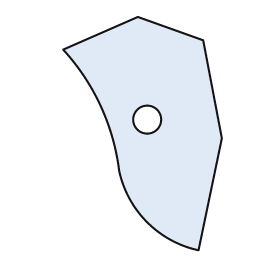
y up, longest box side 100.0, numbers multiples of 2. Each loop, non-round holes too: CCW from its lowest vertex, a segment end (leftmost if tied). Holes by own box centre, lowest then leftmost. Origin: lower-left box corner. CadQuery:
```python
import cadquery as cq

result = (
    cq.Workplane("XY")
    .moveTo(58.0, 0.0)
    .lineTo(68.0, 48.0)
    .lineTo(60.0, 90.0)
    .lineTo(32.0, 100.0)
    .lineTo(0.0, 86.0)
    .threePointArc((16.0, 62.0), (24.0, 34.0))
    .threePointArc((36.0, 12.0), (58.0, 0.0))
    .close()
    .moveTo(36.0, 56.0)
    .circle(6.0)
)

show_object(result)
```